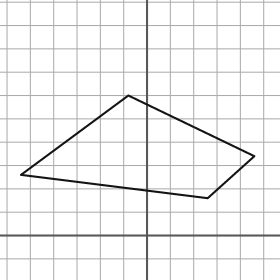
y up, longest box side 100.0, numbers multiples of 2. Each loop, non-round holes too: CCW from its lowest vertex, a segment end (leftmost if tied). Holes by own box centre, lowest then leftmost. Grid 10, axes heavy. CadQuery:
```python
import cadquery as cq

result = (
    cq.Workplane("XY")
    .moveTo(26.0, 16.0)
    .lineTo(46.0, 34.0)
    .lineTo(-8.0, 60.0)
    .lineTo(-54.0, 26.0)
    .close()
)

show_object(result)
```